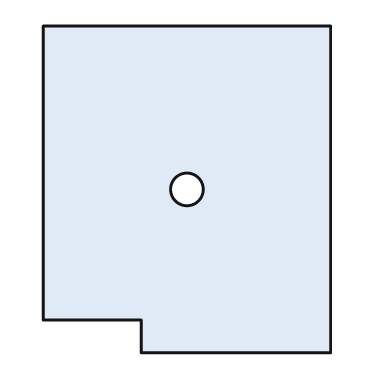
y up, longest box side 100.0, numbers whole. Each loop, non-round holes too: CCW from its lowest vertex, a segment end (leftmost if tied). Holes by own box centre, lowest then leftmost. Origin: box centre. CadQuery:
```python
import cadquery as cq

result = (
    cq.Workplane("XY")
    .moveTo(-14.0, -50.0)
    .lineTo(44.0, -50.0)
    .lineTo(44.0, 50.0)
    .lineTo(-44.0, 50.0)
    .lineTo(-44.0, -40.0)
    .lineTo(-14.0, -40.0)
    .close()
    .moveTo(0.0, 0.0)
    .circle(5.0)
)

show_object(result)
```